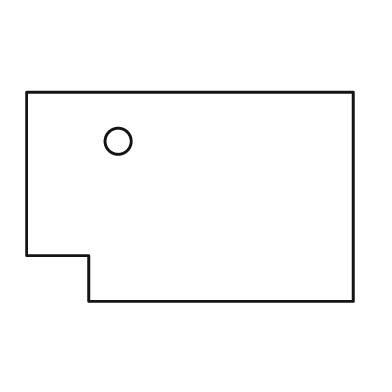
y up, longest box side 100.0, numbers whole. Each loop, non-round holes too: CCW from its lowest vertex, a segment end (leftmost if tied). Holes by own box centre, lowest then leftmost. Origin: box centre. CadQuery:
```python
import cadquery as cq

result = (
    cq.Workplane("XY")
    .moveTo(-31.0, -32.0)
    .lineTo(50.0, -32.0)
    .lineTo(50.0, 32.0)
    .lineTo(-50.0, 32.0)
    .lineTo(-50.0, -18.0)
    .lineTo(-31.0, -18.0)
    .close()
    .moveTo(-22.0, 17.0)
    .circle(4.0)
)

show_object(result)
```